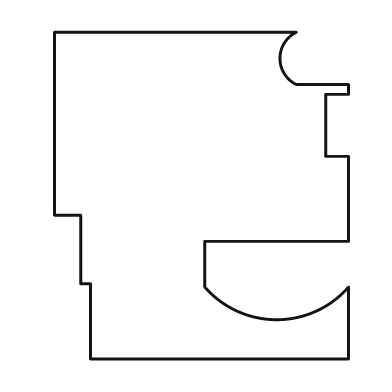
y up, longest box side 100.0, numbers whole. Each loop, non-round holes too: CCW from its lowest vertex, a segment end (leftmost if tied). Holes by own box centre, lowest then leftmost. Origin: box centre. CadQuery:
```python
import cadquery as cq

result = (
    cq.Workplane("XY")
    .moveTo(-34.0, -50.0)
    .lineTo(45.0, -50.0)
    .lineTo(45.0, -28.0)
    .threePointArc((23.0, -38.0), (1.0, -28.0))
    .lineTo(1.0, -14.0)
    .lineTo(45.0, -14.0)
    .lineTo(45.0, 12.0)
    .lineTo(38.0, 12.0)
    .lineTo(38.0, 31.0)
    .lineTo(45.0, 31.0)
    .lineTo(45.0, 34.0)
    .lineTo(29.0, 34.0)
    .threePointArc((24.0, 42.0), (29.0, 50.0))
    .lineTo(-45.0, 50.0)
    .lineTo(-45.0, -6.0)
    .lineTo(-37.0, -6.0)
    .lineTo(-37.0, -27.0)
    .lineTo(-34.0, -27.0)
    .close()
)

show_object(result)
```